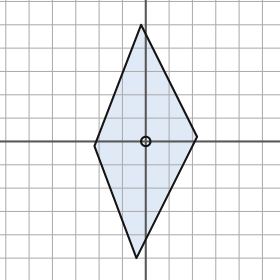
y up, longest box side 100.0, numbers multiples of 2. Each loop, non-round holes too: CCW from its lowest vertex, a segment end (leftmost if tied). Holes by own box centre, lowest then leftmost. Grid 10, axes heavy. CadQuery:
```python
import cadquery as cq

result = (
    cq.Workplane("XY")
    .moveTo(-4.0, -50.0)
    .lineTo(22.0, 2.0)
    .lineTo(-2.0, 50.0)
    .lineTo(-22.0, -2.0)
    .close()
    .moveTo(0.0, 0.0)
    .circle(2.0)
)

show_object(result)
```